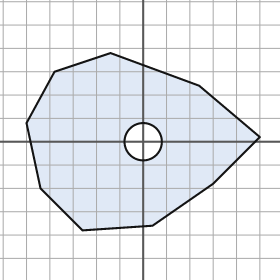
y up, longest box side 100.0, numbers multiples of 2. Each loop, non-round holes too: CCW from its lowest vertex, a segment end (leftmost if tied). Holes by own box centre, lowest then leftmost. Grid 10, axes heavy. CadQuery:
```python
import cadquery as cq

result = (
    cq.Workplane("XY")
    .moveTo(-26.0, -38.0)
    .lineTo(4.0, -36.0)
    .lineTo(30.0, -18.0)
    .lineTo(50.0, 2.0)
    .lineTo(24.0, 24.0)
    .lineTo(-14.0, 38.0)
    .lineTo(-38.0, 30.0)
    .lineTo(-50.0, 8.0)
    .lineTo(-44.0, -20.0)
    .close()
    .moveTo(0.0, 0.0)
    .circle(8.0)
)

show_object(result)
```